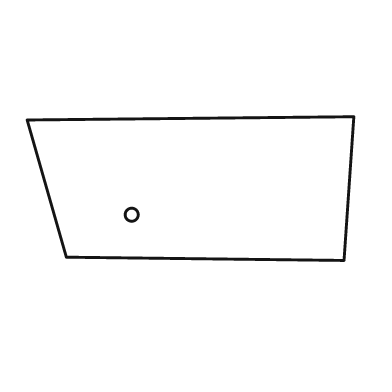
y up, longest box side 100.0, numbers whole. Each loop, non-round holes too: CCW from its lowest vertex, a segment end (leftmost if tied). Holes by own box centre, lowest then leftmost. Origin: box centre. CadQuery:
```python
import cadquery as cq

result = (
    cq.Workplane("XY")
    .moveTo(47.0, -22.0)
    .lineTo(50.0, 22.0)
    .lineTo(-50.0, 21.0)
    .lineTo(-38.0, -21.0)
    .close()
    .moveTo(-18.0, -8.0)
    .circle(2.0)
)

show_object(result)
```